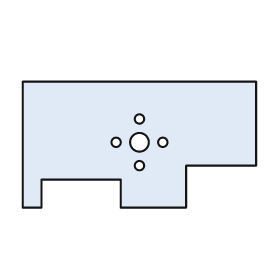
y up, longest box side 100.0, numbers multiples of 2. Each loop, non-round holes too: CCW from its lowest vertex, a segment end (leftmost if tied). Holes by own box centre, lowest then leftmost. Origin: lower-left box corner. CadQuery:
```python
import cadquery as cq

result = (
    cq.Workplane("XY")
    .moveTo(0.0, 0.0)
    .lineTo(8.0, 0.0)
    .lineTo(8.0, 12.0)
    .lineTo(42.0, 12.0)
    .lineTo(42.0, 0.0)
    .lineTo(70.0, 0.0)
    .lineTo(70.0, 18.0)
    .lineTo(100.0, 18.0)
    .lineTo(100.0, 54.0)
    .lineTo(0.0, 54.0)
    .close()
    .moveTo(50.0, 18.0)
    .circle(2.0)
    .moveTo(40.0, 28.0)
    .circle(2.0)
    .moveTo(50.0, 28.0)
    .circle(4.0)
    .moveTo(60.0, 28.0)
    .circle(2.0)
    .moveTo(50.0, 38.0)
    .circle(2.0)
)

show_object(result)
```